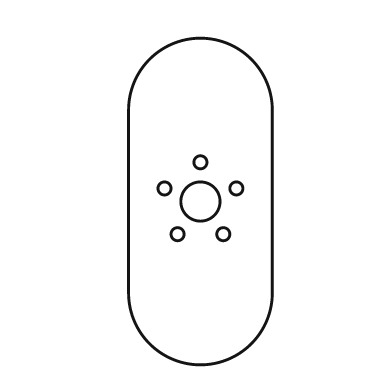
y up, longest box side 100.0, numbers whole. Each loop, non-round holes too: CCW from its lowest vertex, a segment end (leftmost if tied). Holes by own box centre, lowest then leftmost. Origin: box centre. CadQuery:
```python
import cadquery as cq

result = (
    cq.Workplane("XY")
    .moveTo(-22.0, -28.0)
    .threePointArc((0.0, -50.0), (22.0, -28.0))
    .lineTo(22.0, 28.0)
    .threePointArc((0.0, 50.0), (-22.0, 28.0))
    .close()
    .moveTo(-7.0, -10.0)
    .circle(2.0)
    .moveTo(7.0, -10.0)
    .circle(2.0)
    .moveTo(0.0, 0.0)
    .circle(6.0)
    .moveTo(-11.0, 4.0)
    .circle(2.0)
    .moveTo(11.0, 4.0)
    .circle(2.0)
    .moveTo(0.0, 12.0)
    .circle(2.0)
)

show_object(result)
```